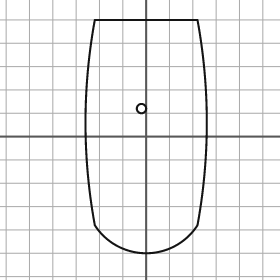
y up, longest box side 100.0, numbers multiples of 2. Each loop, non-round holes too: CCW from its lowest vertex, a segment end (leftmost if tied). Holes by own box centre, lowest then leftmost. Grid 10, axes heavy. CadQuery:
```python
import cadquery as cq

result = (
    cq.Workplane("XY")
    .moveTo(-22.0, -38.0)
    .threePointArc((0.0, -50.0), (22.0, -38.0))
    .threePointArc((26.0, 6.0), (22.0, 50.0))
    .lineTo(-22.0, 50.0)
    .threePointArc((-26.0, 6.0), (-22.0, -38.0))
    .close()
    .moveTo(-2.0, 12.0)
    .circle(2.0)
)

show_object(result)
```